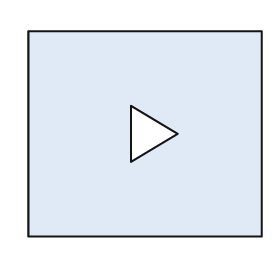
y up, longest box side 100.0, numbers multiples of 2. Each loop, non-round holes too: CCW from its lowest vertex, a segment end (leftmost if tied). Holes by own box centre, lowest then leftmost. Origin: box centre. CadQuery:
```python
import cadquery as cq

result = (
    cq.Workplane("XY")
    .moveTo(-50.0, -44.0)
    .lineTo(50.0, -44.0)
    .lineTo(50.0, 44.0)
    .lineTo(-50.0, 44.0)
    .close()
    .moveTo(-6.0, -12.0)
    .lineTo(14.0, 0.0)
    .lineTo(-6.0, 12.0)
    .close()
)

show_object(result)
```